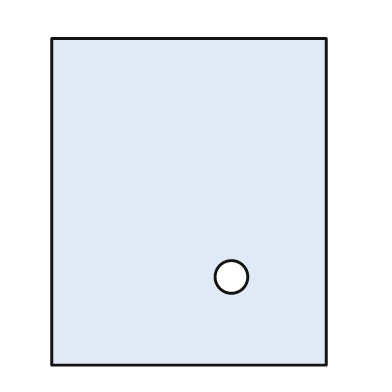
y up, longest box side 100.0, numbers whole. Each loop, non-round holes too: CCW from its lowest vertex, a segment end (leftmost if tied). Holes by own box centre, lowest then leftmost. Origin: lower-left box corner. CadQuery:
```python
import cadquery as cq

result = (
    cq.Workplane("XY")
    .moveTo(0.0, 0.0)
    .lineTo(84.0, 0.0)
    .lineTo(84.0, 100.0)
    .lineTo(0.0, 100.0)
    .close()
    .moveTo(55.0, 27.0)
    .circle(5.0)
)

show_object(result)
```